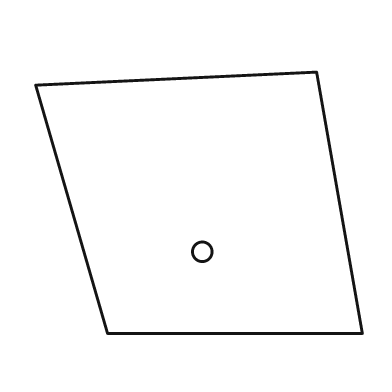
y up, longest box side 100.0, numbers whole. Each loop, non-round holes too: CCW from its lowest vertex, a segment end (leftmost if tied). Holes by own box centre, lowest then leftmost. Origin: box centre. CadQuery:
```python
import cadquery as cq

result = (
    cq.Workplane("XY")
    .moveTo(-28.0, -40.0)
    .lineTo(50.0, -40.0)
    .lineTo(36.0, 40.0)
    .lineTo(-50.0, 36.0)
    .close()
    .moveTo(1.0, -15.0)
    .circle(3.0)
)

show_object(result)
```